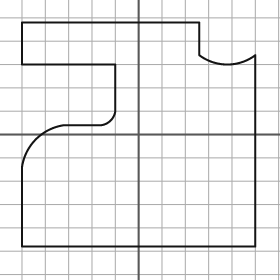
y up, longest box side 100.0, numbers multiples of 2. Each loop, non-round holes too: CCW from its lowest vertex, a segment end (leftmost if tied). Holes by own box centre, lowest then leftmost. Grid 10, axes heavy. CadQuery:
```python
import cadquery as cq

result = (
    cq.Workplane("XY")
    .moveTo(-50.0, -48.0)
    .lineTo(50.0, -48.0)
    .lineTo(50.0, 34.0)
    .threePointArc((38.0, 30.0), (26.0, 34.0))
    .lineTo(26.0, 48.0)
    .lineTo(-50.0, 48.0)
    .lineTo(-50.0, 30.0)
    .lineTo(-10.0, 30.0)
    .lineTo(-10.0, 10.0)
    .threePointArc((-12.0, 6.0), (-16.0, 4.0))
    .lineTo(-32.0, 4.0)
    .threePointArc((-44.0, -2.0), (-50.0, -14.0))
    .close()
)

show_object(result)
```